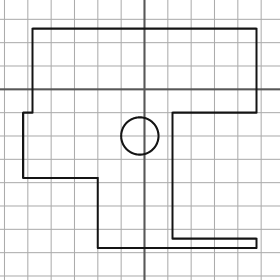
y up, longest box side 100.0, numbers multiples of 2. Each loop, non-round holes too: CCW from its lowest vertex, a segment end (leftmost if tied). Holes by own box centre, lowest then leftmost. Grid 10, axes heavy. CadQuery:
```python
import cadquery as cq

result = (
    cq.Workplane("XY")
    .moveTo(-20.0, -68.0)
    .lineTo(48.0, -68.0)
    .lineTo(48.0, -64.0)
    .lineTo(12.0, -64.0)
    .lineTo(12.0, -10.0)
    .lineTo(48.0, -10.0)
    .lineTo(48.0, 26.0)
    .lineTo(-48.0, 26.0)
    .lineTo(-48.0, -10.0)
    .lineTo(-52.0, -10.0)
    .lineTo(-52.0, -38.0)
    .lineTo(-20.0, -38.0)
    .close()
    .moveTo(-2.0, -20.0)
    .circle(8.0)
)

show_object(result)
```